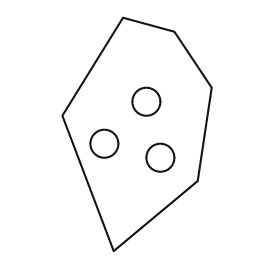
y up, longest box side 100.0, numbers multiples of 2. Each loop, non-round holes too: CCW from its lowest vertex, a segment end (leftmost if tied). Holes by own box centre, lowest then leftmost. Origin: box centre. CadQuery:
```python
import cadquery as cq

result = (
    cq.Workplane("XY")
    .moveTo(-10.0, -50.0)
    .lineTo(26.0, -20.0)
    .lineTo(32.0, 20.0)
    .lineTo(16.0, 44.0)
    .lineTo(-6.0, 50.0)
    .lineTo(-32.0, 8.0)
    .close()
    .moveTo(10.0, -10.0)
    .circle(6.0)
    .moveTo(-14.0, -4.0)
    .circle(6.0)
    .moveTo(4.0, 14.0)
    .circle(6.0)
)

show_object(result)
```